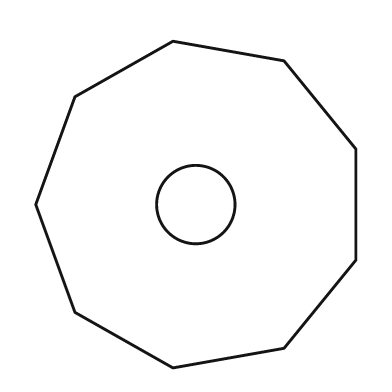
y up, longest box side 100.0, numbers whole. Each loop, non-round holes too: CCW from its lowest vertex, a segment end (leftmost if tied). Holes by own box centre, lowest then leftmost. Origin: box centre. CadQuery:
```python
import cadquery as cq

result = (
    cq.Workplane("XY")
    .moveTo(-7.0, -50.0)
    .lineTo(27.0, -44.0)
    .lineTo(49.0, -17.0)
    .lineTo(49.0, 17.0)
    .lineTo(27.0, 44.0)
    .lineTo(-7.0, 50.0)
    .lineTo(-37.0, 33.0)
    .lineTo(-49.0, 0.0)
    .lineTo(-37.0, -33.0)
    .close()
    .moveTo(0.0, 0.0)
    .circle(12.0)
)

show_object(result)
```